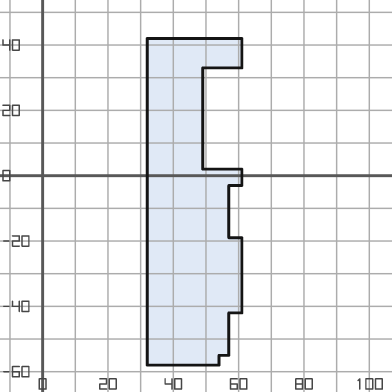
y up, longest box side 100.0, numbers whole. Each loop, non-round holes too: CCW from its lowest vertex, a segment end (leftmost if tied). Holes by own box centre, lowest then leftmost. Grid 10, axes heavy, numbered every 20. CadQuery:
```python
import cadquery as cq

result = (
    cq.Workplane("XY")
    .moveTo(32.0, -58.0)
    .lineTo(54.0, -58.0)
    .lineTo(54.0, -55.0)
    .lineTo(57.0, -55.0)
    .lineTo(57.0, -42.0)
    .lineTo(61.0, -42.0)
    .lineTo(61.0, -19.0)
    .lineTo(57.0, -19.0)
    .lineTo(57.0, -3.0)
    .lineTo(61.0, -3.0)
    .lineTo(61.0, 2.0)
    .lineTo(49.0, 2.0)
    .lineTo(49.0, 33.0)
    .lineTo(61.0, 33.0)
    .lineTo(61.0, 42.0)
    .lineTo(32.0, 42.0)
    .close()
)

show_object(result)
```